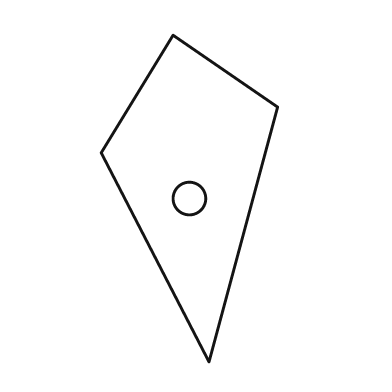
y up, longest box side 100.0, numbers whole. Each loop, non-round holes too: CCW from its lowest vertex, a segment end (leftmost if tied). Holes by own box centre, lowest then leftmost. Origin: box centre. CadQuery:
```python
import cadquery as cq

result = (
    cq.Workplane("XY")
    .moveTo(6.0, -50.0)
    .lineTo(27.0, 28.0)
    .lineTo(-5.0, 50.0)
    .lineTo(-27.0, 14.0)
    .close()
    .moveTo(0.0, 0.0)
    .circle(5.0)
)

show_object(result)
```